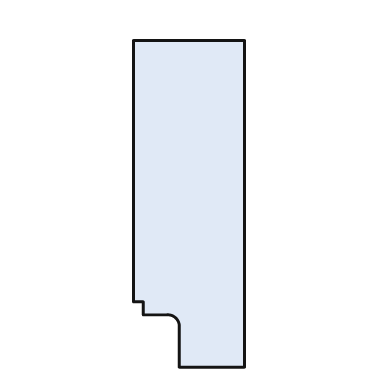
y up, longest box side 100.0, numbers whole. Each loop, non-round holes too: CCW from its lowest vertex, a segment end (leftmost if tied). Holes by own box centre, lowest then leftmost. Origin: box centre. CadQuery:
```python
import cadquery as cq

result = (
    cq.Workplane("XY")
    .moveTo(-3.0, -50.0)
    .lineTo(17.0, -50.0)
    .lineTo(17.0, 50.0)
    .lineTo(-17.0, 50.0)
    .lineTo(-17.0, -30.0)
    .lineTo(-14.0, -30.0)
    .lineTo(-14.0, -34.0)
    .lineTo(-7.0, -34.0)
    .threePointArc((-4.0, -35.0), (-3.0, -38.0))
    .close()
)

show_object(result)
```